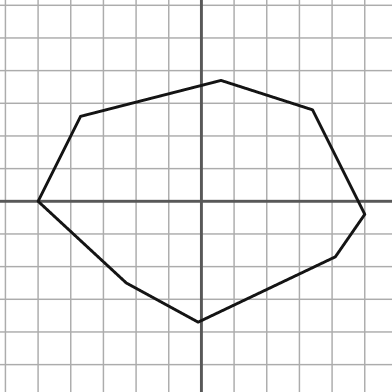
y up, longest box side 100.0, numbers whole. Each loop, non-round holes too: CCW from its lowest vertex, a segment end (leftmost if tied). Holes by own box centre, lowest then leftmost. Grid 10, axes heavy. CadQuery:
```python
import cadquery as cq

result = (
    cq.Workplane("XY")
    .moveTo(-1.0, -37.0)
    .lineTo(41.0, -17.0)
    .lineTo(50.0, -4.0)
    .lineTo(34.0, 28.0)
    .lineTo(6.0, 37.0)
    .lineTo(-37.0, 26.0)
    .lineTo(-50.0, 0.0)
    .lineTo(-23.0, -25.0)
    .close()
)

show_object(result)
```